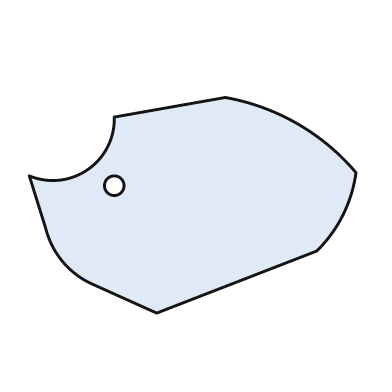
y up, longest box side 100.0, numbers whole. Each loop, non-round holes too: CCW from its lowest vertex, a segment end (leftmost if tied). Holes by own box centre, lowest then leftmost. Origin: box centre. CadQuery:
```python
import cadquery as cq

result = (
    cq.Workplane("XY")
    .moveTo(-11.0, -33.0)
    .lineTo(38.0, -14.0)
    .threePointArc((46.0, -3.0), (50.0, 10.0))
    .threePointArc((32.0, 25.0), (10.0, 33.0))
    .lineTo(-24.0, 27.0)
    .threePointArc((-32.0, 11.0), (-50.0, 9.0))
    .lineTo(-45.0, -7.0)
    .threePointArc((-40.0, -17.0), (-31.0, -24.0))
    .close()
    .moveTo(-24.0, 6.0)
    .circle(3.0)
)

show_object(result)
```